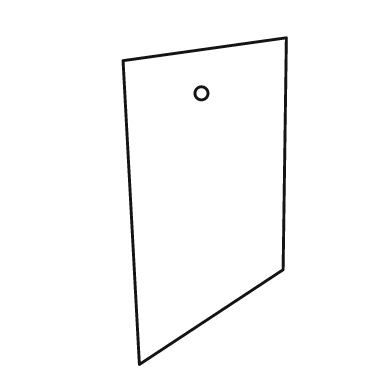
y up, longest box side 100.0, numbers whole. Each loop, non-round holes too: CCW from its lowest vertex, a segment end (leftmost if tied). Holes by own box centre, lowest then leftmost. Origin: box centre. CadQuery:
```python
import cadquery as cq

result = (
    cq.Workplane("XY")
    .moveTo(-20.0, -50.0)
    .lineTo(24.0, -21.0)
    .lineTo(25.0, 50.0)
    .lineTo(-25.0, 43.0)
    .close()
    .moveTo(-1.0, 33.0)
    .circle(2.0)
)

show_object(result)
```